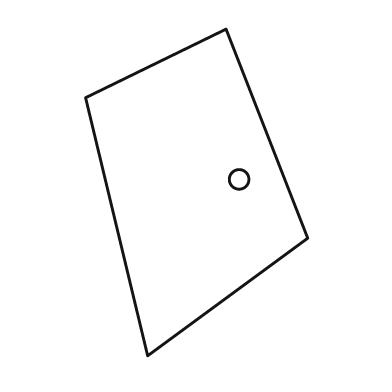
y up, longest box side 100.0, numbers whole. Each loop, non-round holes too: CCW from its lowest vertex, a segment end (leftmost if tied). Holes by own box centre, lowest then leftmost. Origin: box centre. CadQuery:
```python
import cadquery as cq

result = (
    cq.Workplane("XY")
    .moveTo(-15.0, -50.0)
    .lineTo(34.0, -14.0)
    .lineTo(9.0, 50.0)
    .lineTo(-34.0, 29.0)
    .close()
    .moveTo(13.0, 4.0)
    .circle(3.0)
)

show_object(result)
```